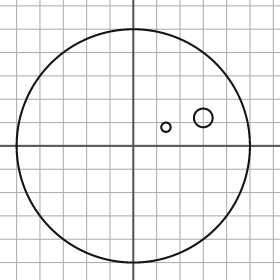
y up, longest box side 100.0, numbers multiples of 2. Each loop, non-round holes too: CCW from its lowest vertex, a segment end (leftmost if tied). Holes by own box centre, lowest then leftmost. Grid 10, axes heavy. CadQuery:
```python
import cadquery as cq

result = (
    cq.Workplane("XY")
    .moveTo(0.0, 0.0)
    .circle(50.0)
    .moveTo(14.0, 8.0)
    .circle(2.0)
    .moveTo(30.0, 12.0)
    .circle(4.0)
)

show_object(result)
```